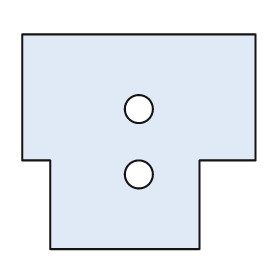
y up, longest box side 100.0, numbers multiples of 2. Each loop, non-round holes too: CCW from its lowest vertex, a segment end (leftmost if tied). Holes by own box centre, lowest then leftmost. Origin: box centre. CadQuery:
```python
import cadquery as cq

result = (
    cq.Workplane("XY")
    .moveTo(-38.0, -46.0)
    .lineTo(26.0, -46.0)
    .lineTo(26.0, -8.0)
    .lineTo(50.0, -8.0)
    .lineTo(50.0, 46.0)
    .lineTo(-50.0, 46.0)
    .lineTo(-50.0, -8.0)
    .lineTo(-38.0, -8.0)
    .close()
    .moveTo(0.0, -14.0)
    .circle(6.0)
    .moveTo(0.0, 14.0)
    .circle(6.0)
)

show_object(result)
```